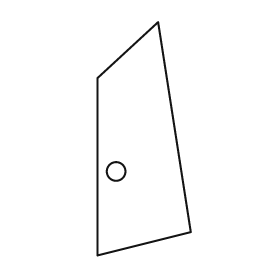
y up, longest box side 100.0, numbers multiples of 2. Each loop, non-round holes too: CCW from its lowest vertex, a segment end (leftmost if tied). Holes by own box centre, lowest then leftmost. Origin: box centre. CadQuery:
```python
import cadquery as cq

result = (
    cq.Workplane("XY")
    .moveTo(-20.0, -50.0)
    .lineTo(20.0, -40.0)
    .lineTo(6.0, 50.0)
    .lineTo(-20.0, 26.0)
    .close()
    .moveTo(-12.0, -14.0)
    .circle(4.0)
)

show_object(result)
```